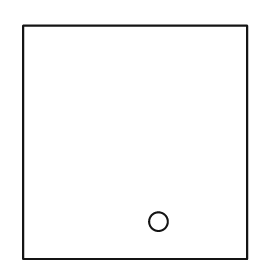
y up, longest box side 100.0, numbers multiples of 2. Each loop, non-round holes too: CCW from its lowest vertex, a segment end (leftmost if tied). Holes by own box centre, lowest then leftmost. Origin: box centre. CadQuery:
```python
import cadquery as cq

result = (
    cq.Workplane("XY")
    .moveTo(-48.0, -50.0)
    .lineTo(48.0, -50.0)
    .lineTo(48.0, 50.0)
    .lineTo(-48.0, 50.0)
    .close()
    .moveTo(10.0, -34.0)
    .circle(4.0)
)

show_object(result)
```